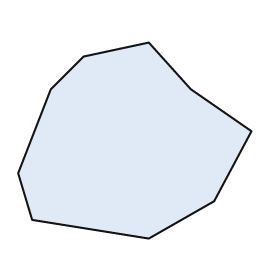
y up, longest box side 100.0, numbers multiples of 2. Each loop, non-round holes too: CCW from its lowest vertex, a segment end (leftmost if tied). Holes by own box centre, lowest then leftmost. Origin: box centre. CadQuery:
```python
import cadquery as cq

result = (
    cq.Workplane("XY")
    .moveTo(6.0, -42.0)
    .lineTo(34.0, -26.0)
    .lineTo(50.0, 4.0)
    .lineTo(24.0, 22.0)
    .lineTo(6.0, 42.0)
    .lineTo(-22.0, 36.0)
    .lineTo(-36.0, 22.0)
    .lineTo(-50.0, -14.0)
    .lineTo(-44.0, -34.0)
    .close()
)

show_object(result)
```